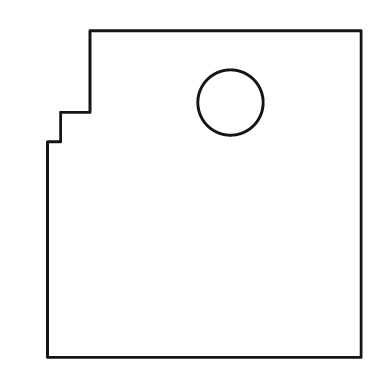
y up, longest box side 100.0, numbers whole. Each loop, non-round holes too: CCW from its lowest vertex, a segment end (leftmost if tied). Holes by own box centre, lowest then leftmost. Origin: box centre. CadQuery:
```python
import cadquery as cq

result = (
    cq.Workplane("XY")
    .moveTo(-48.0, -50.0)
    .lineTo(48.0, -50.0)
    .lineTo(48.0, 50.0)
    .lineTo(-35.0, 50.0)
    .lineTo(-35.0, 25.0)
    .lineTo(-44.0, 25.0)
    .lineTo(-44.0, 16.0)
    .lineTo(-48.0, 16.0)
    .close()
    .moveTo(8.0, 28.0)
    .circle(10.0)
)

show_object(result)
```